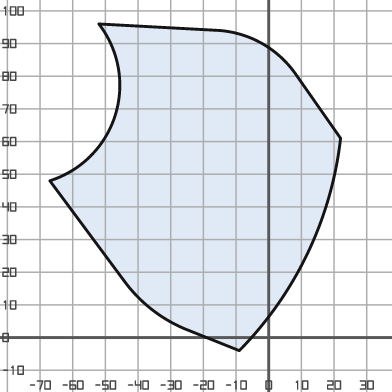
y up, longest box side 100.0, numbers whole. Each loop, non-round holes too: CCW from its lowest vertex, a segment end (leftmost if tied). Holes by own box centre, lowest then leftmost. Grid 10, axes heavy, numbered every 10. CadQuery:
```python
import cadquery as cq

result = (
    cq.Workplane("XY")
    .moveTo(-9.0, -4.0)
    .threePointArc((12.0, 26.0), (22.0, 61.0))
    .lineTo(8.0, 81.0)
    .threePointArc((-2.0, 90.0), (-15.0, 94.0))
    .lineTo(-52.0, 96.0)
    .threePointArc((-47.0, 68.0), (-67.0, 48.0))
    .lineTo(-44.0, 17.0)
    .threePointArc((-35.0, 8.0), (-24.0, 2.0))
    .close()
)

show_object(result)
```